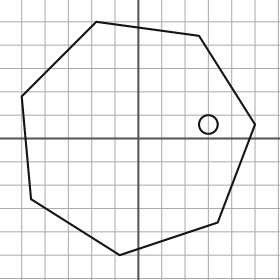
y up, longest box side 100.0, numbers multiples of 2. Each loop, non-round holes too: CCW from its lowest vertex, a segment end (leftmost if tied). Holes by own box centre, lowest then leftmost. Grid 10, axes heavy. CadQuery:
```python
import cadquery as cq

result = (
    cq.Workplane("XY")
    .moveTo(-8.0, -50.0)
    .lineTo(34.0, -36.0)
    .lineTo(50.0, 6.0)
    .lineTo(26.0, 44.0)
    .lineTo(-18.0, 50.0)
    .lineTo(-50.0, 18.0)
    .lineTo(-46.0, -26.0)
    .close()
    .moveTo(30.0, 6.0)
    .circle(4.0)
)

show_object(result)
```